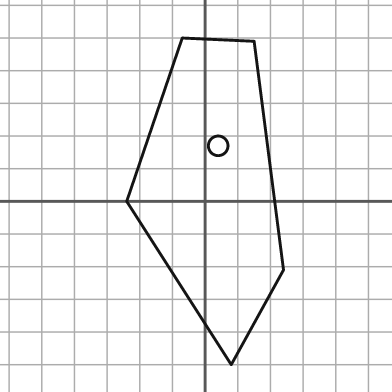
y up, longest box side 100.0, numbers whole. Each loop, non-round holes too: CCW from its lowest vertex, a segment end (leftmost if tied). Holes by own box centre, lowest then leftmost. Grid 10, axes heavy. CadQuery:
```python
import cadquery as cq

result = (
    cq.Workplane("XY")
    .moveTo(8.0, -50.0)
    .lineTo(24.0, -21.0)
    .lineTo(15.0, 49.0)
    .lineTo(-7.0, 50.0)
    .lineTo(-24.0, 0.0)
    .close()
    .moveTo(4.0, 17.0)
    .circle(3.0)
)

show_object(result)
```